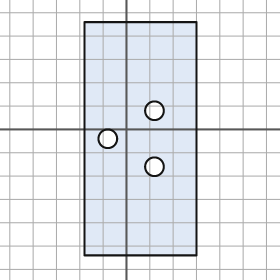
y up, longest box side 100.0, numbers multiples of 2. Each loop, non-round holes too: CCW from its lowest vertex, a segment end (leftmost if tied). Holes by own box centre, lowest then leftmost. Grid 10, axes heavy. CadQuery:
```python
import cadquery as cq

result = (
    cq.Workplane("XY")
    .moveTo(-18.0, -54.0)
    .lineTo(30.0, -54.0)
    .lineTo(30.0, 46.0)
    .lineTo(-18.0, 46.0)
    .close()
    .moveTo(12.0, -16.0)
    .circle(4.0)
    .moveTo(-8.0, -4.0)
    .circle(4.0)
    .moveTo(12.0, 8.0)
    .circle(4.0)
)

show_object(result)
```